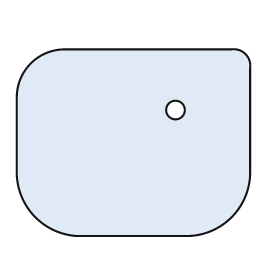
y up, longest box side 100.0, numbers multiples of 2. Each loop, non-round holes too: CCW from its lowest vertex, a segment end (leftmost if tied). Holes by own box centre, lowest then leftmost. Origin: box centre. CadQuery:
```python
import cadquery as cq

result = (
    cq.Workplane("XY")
    .moveTo(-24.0, -40.0)
    .lineTo(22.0, -40.0)
    .threePointArc((42.0, -32.0), (50.0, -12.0))
    .lineTo(50.0, 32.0)
    .threePointArc((48.0, 38.0), (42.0, 40.0))
    .lineTo(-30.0, 40.0)
    .threePointArc((-44.0, 34.0), (-50.0, 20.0))
    .lineTo(-50.0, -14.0)
    .threePointArc((-42.0, -32.0), (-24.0, -40.0))
    .close()
    .moveTo(18.0, 14.0)
    .circle(4.0)
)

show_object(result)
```